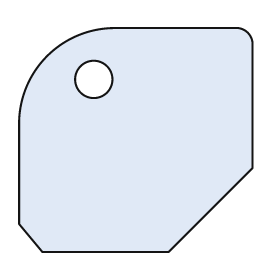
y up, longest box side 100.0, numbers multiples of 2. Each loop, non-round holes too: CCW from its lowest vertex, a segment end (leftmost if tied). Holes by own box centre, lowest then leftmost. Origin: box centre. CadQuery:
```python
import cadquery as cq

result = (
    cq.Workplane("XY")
    .moveTo(-40.0, -48.0)
    .lineTo(14.0, -48.0)
    .lineTo(50.0, -12.0)
    .lineTo(50.0, 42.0)
    .threePointArc((48.0, 46.0), (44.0, 48.0))
    .lineTo(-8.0, 48.0)
    .threePointArc((-38.0, 36.0), (-50.0, 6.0))
    .lineTo(-50.0, -36.0)
    .close()
    .moveTo(-18.0, 26.0)
    .circle(8.0)
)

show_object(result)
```